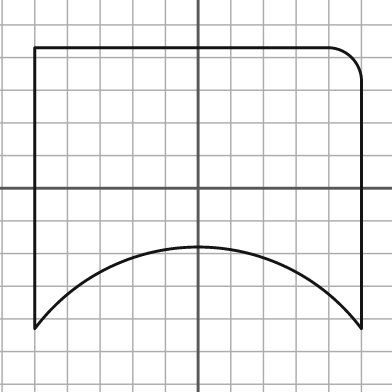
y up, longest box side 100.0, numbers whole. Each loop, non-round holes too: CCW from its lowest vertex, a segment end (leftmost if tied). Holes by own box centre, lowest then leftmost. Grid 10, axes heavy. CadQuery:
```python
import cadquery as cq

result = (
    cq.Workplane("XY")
    .moveTo(-50.0, -43.0)
    .threePointArc((0.0, -18.0), (50.0, -43.0))
    .lineTo(50.0, 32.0)
    .threePointArc((47.0, 40.0), (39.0, 43.0))
    .lineTo(-50.0, 43.0)
    .close()
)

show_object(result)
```